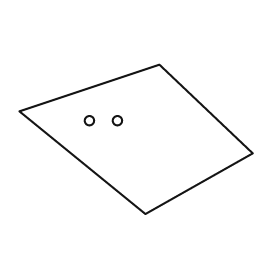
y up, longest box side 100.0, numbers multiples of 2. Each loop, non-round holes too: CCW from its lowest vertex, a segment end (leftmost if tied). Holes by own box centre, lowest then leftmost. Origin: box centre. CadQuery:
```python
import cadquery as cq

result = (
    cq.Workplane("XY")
    .moveTo(4.0, -32.0)
    .lineTo(50.0, -6.0)
    .lineTo(10.0, 32.0)
    .lineTo(-50.0, 12.0)
    .close()
    .moveTo(-20.0, 8.0)
    .circle(2.0)
    .moveTo(-8.0, 8.0)
    .circle(2.0)
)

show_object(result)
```